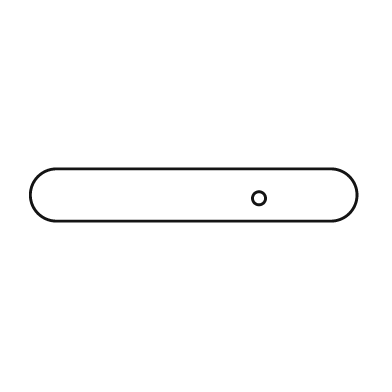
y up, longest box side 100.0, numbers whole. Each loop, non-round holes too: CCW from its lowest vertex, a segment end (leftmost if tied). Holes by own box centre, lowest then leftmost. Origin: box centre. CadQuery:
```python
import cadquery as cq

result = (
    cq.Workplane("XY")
    .moveTo(-42.0, -8.0)
    .lineTo(42.0, -8.0)
    .threePointArc((50.0, 0.0), (42.0, 8.0))
    .lineTo(-42.0, 8.0)
    .threePointArc((-50.0, 0.0), (-42.0, -8.0))
    .close()
    .moveTo(20.0, -1.0)
    .circle(2.0)
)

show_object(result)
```